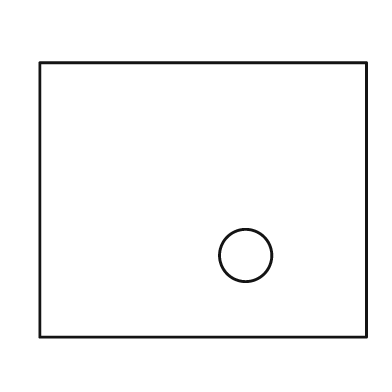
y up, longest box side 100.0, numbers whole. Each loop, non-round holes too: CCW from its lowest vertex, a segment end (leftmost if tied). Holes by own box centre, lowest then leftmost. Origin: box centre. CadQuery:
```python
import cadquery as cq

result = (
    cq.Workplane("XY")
    .moveTo(-50.0, -42.0)
    .lineTo(50.0, -42.0)
    .lineTo(50.0, 42.0)
    .lineTo(-50.0, 42.0)
    .close()
    .moveTo(13.0, -17.0)
    .circle(8.0)
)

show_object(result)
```